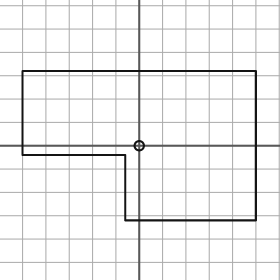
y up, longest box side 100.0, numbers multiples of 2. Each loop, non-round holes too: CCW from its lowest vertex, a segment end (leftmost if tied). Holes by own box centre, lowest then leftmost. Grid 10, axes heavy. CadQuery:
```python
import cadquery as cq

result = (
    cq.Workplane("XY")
    .moveTo(-6.0, -32.0)
    .lineTo(50.0, -32.0)
    .lineTo(50.0, 32.0)
    .lineTo(-50.0, 32.0)
    .lineTo(-50.0, -4.0)
    .lineTo(-6.0, -4.0)
    .close()
    .moveTo(0.0, 0.0)
    .circle(2.0)
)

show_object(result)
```